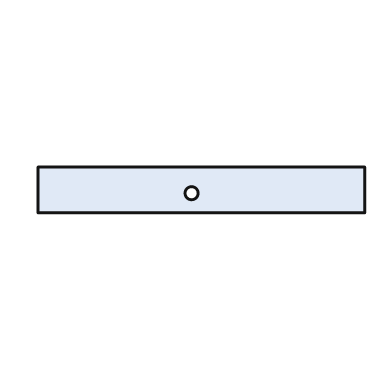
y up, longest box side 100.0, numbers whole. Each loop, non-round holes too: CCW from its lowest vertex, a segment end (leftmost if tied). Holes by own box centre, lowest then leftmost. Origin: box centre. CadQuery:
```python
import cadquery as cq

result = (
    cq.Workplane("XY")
    .moveTo(-50.0, -7.0)
    .lineTo(50.0, -7.0)
    .lineTo(50.0, 7.0)
    .lineTo(-50.0, 7.0)
    .close()
    .moveTo(-3.0, -1.0)
    .circle(2.0)
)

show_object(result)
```